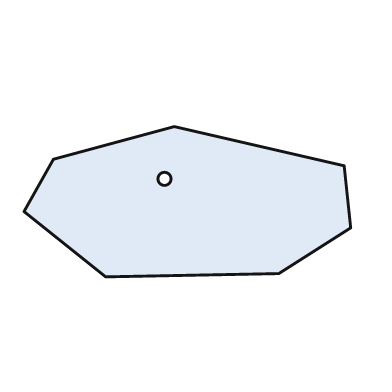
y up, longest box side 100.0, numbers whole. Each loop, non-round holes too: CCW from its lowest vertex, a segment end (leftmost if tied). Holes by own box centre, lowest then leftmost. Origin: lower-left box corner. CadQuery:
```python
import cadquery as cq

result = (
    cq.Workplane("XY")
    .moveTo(25.0, 0.0)
    .lineTo(78.0, 1.0)
    .lineTo(100.0, 15.0)
    .lineTo(98.0, 34.0)
    .lineTo(46.0, 46.0)
    .lineTo(9.0, 36.0)
    .lineTo(0.0, 20.0)
    .close()
    .moveTo(43.0, 30.0)
    .circle(2.0)
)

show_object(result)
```